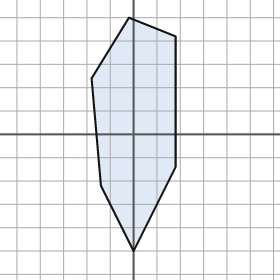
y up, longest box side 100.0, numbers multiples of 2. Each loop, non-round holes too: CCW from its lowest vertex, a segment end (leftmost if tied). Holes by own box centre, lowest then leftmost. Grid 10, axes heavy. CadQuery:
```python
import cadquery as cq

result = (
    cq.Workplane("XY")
    .moveTo(0.0, -50.0)
    .lineTo(18.0, -14.0)
    .lineTo(18.0, 42.0)
    .lineTo(-2.0, 50.0)
    .lineTo(-18.0, 24.0)
    .lineTo(-14.0, -22.0)
    .close()
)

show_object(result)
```